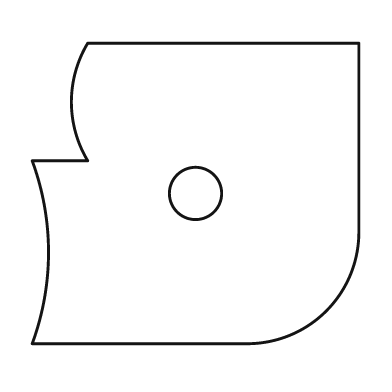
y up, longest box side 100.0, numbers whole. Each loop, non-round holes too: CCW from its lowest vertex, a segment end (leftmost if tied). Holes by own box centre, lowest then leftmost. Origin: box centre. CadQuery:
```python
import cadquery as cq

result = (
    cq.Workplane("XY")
    .moveTo(-50.0, -46.0)
    .lineTo(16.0, -46.0)
    .threePointArc((40.0, -36.0), (50.0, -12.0))
    .lineTo(50.0, 46.0)
    .lineTo(-33.0, 46.0)
    .threePointArc((-38.0, 28.0), (-33.0, 10.0))
    .lineTo(-50.0, 10.0)
    .threePointArc((-45.0, -18.0), (-50.0, -46.0))
    .close()
    .moveTo(0.0, 0.0)
    .circle(8.0)
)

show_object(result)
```